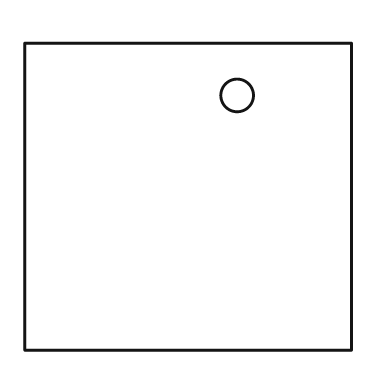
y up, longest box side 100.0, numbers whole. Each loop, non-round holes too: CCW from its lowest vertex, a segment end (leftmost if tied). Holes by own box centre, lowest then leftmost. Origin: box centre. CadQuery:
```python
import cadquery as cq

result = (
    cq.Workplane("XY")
    .moveTo(-50.0, -47.0)
    .lineTo(50.0, -47.0)
    .lineTo(50.0, 47.0)
    .lineTo(-50.0, 47.0)
    .close()
    .moveTo(15.0, 31.0)
    .circle(5.0)
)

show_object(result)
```